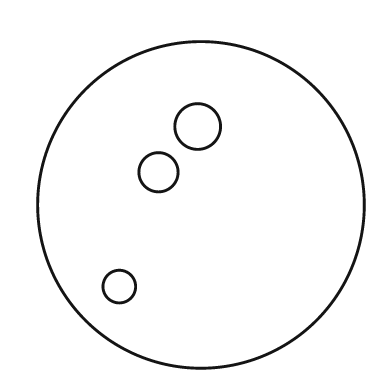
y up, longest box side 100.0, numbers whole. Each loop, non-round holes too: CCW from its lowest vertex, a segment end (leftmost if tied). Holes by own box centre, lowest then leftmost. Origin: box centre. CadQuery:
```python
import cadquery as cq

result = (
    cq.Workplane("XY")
    .moveTo(0.0, 0.0)
    .circle(50.0)
    .moveTo(-25.0, -25.0)
    .circle(5.0)
    .moveTo(-13.0, 10.0)
    .circle(6.0)
    .moveTo(-1.0, 24.0)
    .circle(7.0)
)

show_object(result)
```